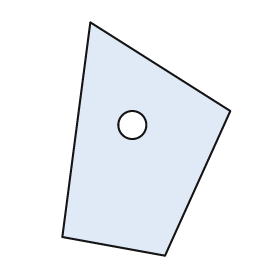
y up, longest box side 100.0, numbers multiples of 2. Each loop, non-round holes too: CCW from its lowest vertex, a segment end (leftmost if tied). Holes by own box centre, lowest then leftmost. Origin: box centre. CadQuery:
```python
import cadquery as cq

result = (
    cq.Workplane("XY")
    .moveTo(8.0, -50.0)
    .lineTo(36.0, 12.0)
    .lineTo(-24.0, 50.0)
    .lineTo(-36.0, -42.0)
    .close()
    .moveTo(-6.0, 6.0)
    .circle(6.0)
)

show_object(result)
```